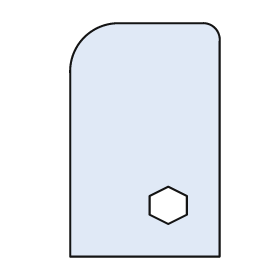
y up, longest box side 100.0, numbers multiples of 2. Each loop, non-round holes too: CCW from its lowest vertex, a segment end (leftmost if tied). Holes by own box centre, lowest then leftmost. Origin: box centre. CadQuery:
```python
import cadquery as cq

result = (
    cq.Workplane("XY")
    .moveTo(-32.0, -50.0)
    .lineTo(32.0, -50.0)
    .lineTo(32.0, 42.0)
    .threePointArc((30.0, 48.0), (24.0, 50.0))
    .lineTo(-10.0, 50.0)
    .threePointArc((-26.0, 44.0), (-32.0, 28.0))
    .close()
    .moveTo(10.0, -36.0)
    .lineTo(18.0, -32.0)
    .lineTo(18.0, -24.0)
    .lineTo(10.0, -20.0)
    .lineTo(2.0, -24.0)
    .lineTo(2.0, -32.0)
    .close()
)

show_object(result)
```